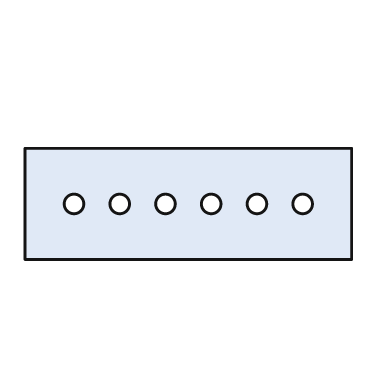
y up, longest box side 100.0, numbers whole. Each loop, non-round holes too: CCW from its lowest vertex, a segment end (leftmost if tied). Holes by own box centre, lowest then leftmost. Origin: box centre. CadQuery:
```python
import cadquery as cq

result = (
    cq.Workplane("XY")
    .moveTo(-50.0, -17.0)
    .lineTo(50.0, -17.0)
    .lineTo(50.0, 17.0)
    .lineTo(-50.0, 17.0)
    .close()
    .moveTo(-35.0, 0.0)
    .circle(3.0)
    .moveTo(-21.0, 0.0)
    .circle(3.0)
    .moveTo(-7.0, 0.0)
    .circle(3.0)
    .moveTo(7.0, 0.0)
    .circle(3.0)
    .moveTo(21.0, 0.0)
    .circle(3.0)
    .moveTo(35.0, 0.0)
    .circle(3.0)
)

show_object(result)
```